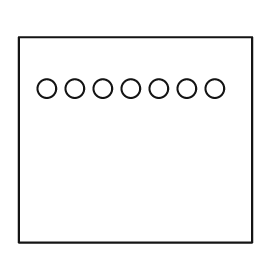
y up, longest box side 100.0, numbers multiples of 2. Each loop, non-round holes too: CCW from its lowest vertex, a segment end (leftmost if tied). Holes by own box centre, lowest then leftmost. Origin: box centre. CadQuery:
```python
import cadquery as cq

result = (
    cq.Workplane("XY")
    .moveTo(-50.0, -44.0)
    .lineTo(50.0, -44.0)
    .lineTo(50.0, 44.0)
    .lineTo(-50.0, 44.0)
    .close()
    .moveTo(-38.0, 22.0)
    .circle(4.0)
    .moveTo(-26.0, 22.0)
    .circle(4.0)
    .moveTo(-14.0, 22.0)
    .circle(4.0)
    .moveTo(-2.0, 22.0)
    .circle(4.0)
    .moveTo(10.0, 22.0)
    .circle(4.0)
    .moveTo(22.0, 22.0)
    .circle(4.0)
    .moveTo(34.0, 22.0)
    .circle(4.0)
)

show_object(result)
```